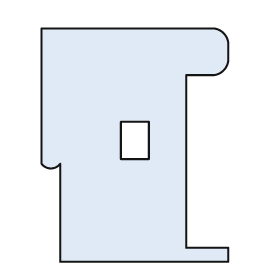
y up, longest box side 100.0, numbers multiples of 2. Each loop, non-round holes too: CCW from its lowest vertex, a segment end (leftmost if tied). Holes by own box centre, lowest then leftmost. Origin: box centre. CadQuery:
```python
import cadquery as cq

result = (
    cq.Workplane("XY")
    .moveTo(-32.0, -50.0)
    .lineTo(40.0, -50.0)
    .lineTo(40.0, -44.0)
    .lineTo(22.0, -44.0)
    .lineTo(22.0, 30.0)
    .lineTo(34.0, 30.0)
    .threePointArc((38.0, 32.0), (40.0, 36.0))
    .lineTo(40.0, 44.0)
    .threePointArc((38.0, 48.0), (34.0, 50.0))
    .lineTo(-40.0, 50.0)
    .lineTo(-40.0, -8.0)
    .threePointArc((-36.0, -10.0), (-32.0, -8.0))
    .close()
    .moveTo(-6.0, -6.0)
    .lineTo(6.0, -6.0)
    .lineTo(6.0, 10.0)
    .lineTo(-6.0, 10.0)
    .close()
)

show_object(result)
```